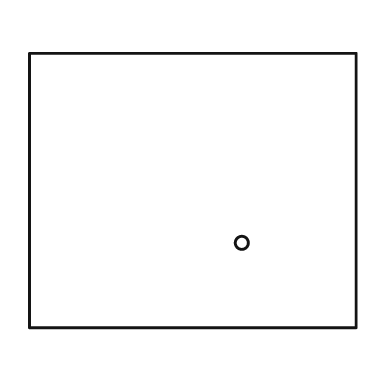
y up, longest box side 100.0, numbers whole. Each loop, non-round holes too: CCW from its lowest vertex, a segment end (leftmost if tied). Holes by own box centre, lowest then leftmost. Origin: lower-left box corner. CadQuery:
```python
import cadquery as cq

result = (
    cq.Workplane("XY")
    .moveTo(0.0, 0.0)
    .lineTo(100.0, 0.0)
    .lineTo(100.0, 84.0)
    .lineTo(0.0, 84.0)
    .close()
    .moveTo(65.0, 26.0)
    .circle(2.0)
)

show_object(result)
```